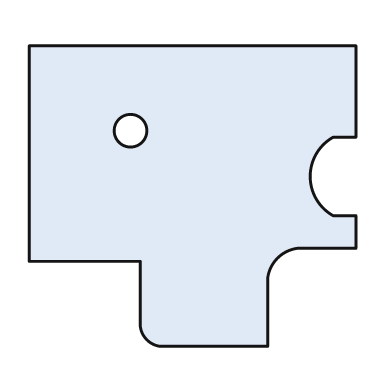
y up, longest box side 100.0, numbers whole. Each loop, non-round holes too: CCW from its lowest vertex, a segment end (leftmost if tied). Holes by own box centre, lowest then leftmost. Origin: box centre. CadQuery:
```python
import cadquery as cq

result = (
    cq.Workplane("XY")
    .moveTo(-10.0, -46.0)
    .lineTo(23.0, -46.0)
    .lineTo(23.0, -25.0)
    .threePointArc((26.0, -19.0), (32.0, -16.0))
    .lineTo(50.0, -16.0)
    .lineTo(50.0, -6.0)
    .lineTo(43.0, -6.0)
    .threePointArc((36.0, 6.0), (43.0, 18.0))
    .lineTo(50.0, 18.0)
    .lineTo(50.0, 46.0)
    .lineTo(-50.0, 46.0)
    .lineTo(-50.0, -20.0)
    .lineTo(-16.0, -20.0)
    .lineTo(-16.0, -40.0)
    .threePointArc((-14.0, -44.0), (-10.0, -46.0))
    .close()
    .moveTo(-19.0, 20.0)
    .circle(5.0)
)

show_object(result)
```